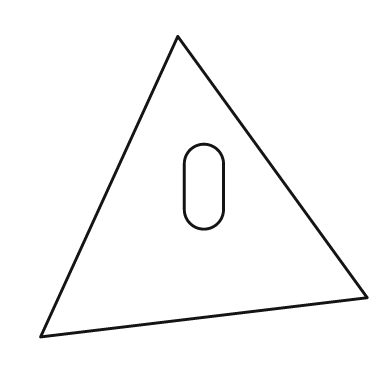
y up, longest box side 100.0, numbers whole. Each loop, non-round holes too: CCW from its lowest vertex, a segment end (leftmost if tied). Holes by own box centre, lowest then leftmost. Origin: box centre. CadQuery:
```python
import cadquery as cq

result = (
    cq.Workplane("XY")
    .moveTo(-50.0, -46.0)
    .lineTo(50.0, -34.0)
    .lineTo(-8.0, 46.0)
    .close()
    .moveTo(-6.0, -7.0)
    .threePointArc((0.0, -13.0), (6.0, -7.0))
    .lineTo(6.0, 7.0)
    .threePointArc((0.0, 13.0), (-6.0, 7.0))
    .close()
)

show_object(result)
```